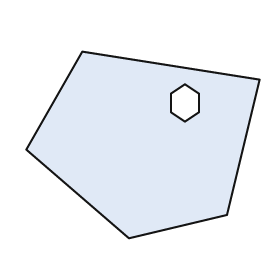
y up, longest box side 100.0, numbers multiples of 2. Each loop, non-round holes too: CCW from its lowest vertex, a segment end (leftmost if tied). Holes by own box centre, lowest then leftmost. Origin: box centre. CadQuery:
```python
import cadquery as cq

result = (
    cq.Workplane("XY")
    .moveTo(-6.0, -40.0)
    .lineTo(36.0, -30.0)
    .lineTo(50.0, 28.0)
    .lineTo(-26.0, 40.0)
    .lineTo(-50.0, -2.0)
    .close()
    .moveTo(18.0, 10.0)
    .lineTo(24.0, 14.0)
    .lineTo(24.0, 22.0)
    .lineTo(18.0, 26.0)
    .lineTo(12.0, 22.0)
    .lineTo(12.0, 14.0)
    .close()
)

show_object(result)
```